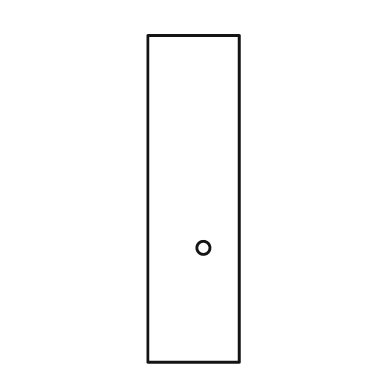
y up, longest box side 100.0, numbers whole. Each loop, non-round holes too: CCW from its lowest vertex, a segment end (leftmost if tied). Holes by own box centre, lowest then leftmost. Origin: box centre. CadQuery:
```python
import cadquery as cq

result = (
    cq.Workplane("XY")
    .moveTo(-14.0, -50.0)
    .lineTo(14.0, -50.0)
    .lineTo(14.0, 50.0)
    .lineTo(-14.0, 50.0)
    .close()
    .moveTo(3.0, -15.0)
    .circle(2.0)
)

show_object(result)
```